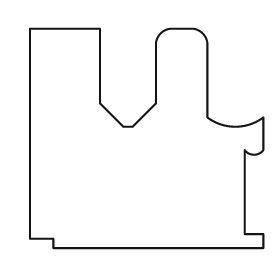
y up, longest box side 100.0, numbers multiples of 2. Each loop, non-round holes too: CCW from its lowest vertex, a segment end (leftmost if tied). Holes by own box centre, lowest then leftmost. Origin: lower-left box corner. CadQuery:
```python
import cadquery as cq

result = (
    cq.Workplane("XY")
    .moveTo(10.0, 0.0)
    .lineTo(100.0, 0.0)
    .lineTo(100.0, 6.0)
    .lineTo(92.0, 6.0)
    .lineTo(92.0, 42.0)
    .threePointArc((96.0, 40.0), (100.0, 42.0))
    .lineTo(100.0, 56.0)
    .threePointArc((88.0, 52.0), (76.0, 56.0))
    .lineTo(76.0, 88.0)
    .threePointArc((74.0, 92.0), (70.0, 94.0))
    .lineTo(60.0, 94.0)
    .threePointArc((56.0, 92.0), (54.0, 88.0))
    .lineTo(54.0, 62.0)
    .lineTo(44.0, 52.0)
    .lineTo(40.0, 52.0)
    .lineTo(30.0, 62.0)
    .lineTo(30.0, 94.0)
    .lineTo(0.0, 94.0)
    .lineTo(0.0, 4.0)
    .lineTo(10.0, 4.0)
    .close()
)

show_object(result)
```